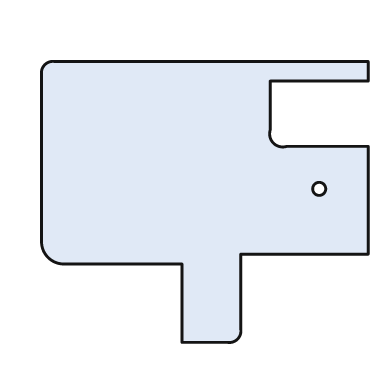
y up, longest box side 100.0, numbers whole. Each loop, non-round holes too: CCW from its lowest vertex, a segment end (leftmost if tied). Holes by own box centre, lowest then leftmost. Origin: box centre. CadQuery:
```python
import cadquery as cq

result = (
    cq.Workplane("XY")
    .moveTo(-7.0, -43.0)
    .lineTo(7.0, -43.0)
    .threePointArc((10.0, -42.0), (11.0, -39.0))
    .lineTo(11.0, -16.0)
    .lineTo(50.0, -16.0)
    .lineTo(50.0, 17.0)
    .lineTo(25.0, 17.0)
    .threePointArc((21.0, 18.0), (20.0, 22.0))
    .lineTo(20.0, 37.0)
    .lineTo(50.0, 37.0)
    .lineTo(50.0, 43.0)
    .lineTo(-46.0, 43.0)
    .threePointArc((-49.0, 42.0), (-50.0, 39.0))
    .lineTo(-50.0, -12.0)
    .threePointArc((-48.0, -17.0), (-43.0, -19.0))
    .lineTo(-7.0, -19.0)
    .close()
    .moveTo(35.0, 4.0)
    .circle(2.0)
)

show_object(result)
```